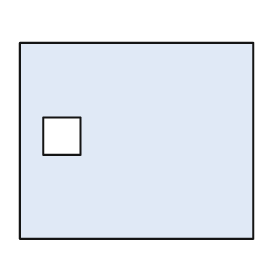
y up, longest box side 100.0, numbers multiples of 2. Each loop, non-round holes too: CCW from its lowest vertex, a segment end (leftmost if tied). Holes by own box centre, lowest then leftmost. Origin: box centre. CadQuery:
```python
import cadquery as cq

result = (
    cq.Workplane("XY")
    .moveTo(-50.0, -42.0)
    .lineTo(50.0, -42.0)
    .lineTo(50.0, 42.0)
    .lineTo(-50.0, 42.0)
    .close()
    .moveTo(-40.0, -6.0)
    .lineTo(-24.0, -6.0)
    .lineTo(-24.0, 10.0)
    .lineTo(-40.0, 10.0)
    .close()
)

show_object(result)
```